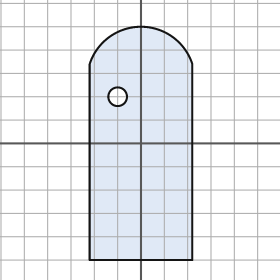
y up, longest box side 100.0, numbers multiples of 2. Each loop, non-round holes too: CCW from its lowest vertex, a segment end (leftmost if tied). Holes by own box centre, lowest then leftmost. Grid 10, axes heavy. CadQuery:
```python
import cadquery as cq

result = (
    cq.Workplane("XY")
    .moveTo(-22.0, -50.0)
    .lineTo(22.0, -50.0)
    .lineTo(22.0, 34.0)
    .threePointArc((0.0, 50.0), (-22.0, 34.0))
    .close()
    .moveTo(-10.0, 20.0)
    .circle(4.0)
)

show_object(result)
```